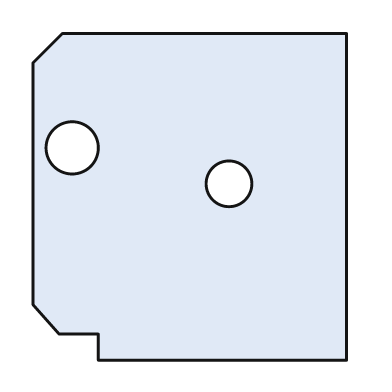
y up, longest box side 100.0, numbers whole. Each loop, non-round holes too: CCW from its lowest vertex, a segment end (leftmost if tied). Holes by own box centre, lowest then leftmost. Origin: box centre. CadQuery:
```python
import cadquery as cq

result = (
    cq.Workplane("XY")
    .moveTo(-28.0, -50.0)
    .lineTo(48.0, -50.0)
    .lineTo(48.0, 50.0)
    .lineTo(-39.0, 50.0)
    .lineTo(-48.0, 41.0)
    .lineTo(-48.0, -33.0)
    .lineTo(-40.0, -42.0)
    .lineTo(-28.0, -42.0)
    .close()
    .moveTo(12.0, 4.0)
    .circle(7.0)
    .moveTo(-36.0, 15.0)
    .circle(8.0)
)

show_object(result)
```